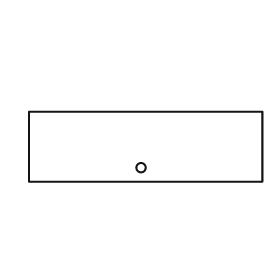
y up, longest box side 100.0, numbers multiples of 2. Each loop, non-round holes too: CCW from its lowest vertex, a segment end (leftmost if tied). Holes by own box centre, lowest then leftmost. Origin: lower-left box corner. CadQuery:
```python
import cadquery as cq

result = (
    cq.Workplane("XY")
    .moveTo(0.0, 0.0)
    .lineTo(100.0, 0.0)
    .lineTo(100.0, 30.0)
    .lineTo(0.0, 30.0)
    .close()
    .moveTo(48.0, 6.0)
    .circle(2.0)
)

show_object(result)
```